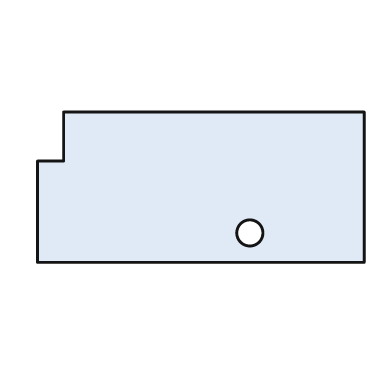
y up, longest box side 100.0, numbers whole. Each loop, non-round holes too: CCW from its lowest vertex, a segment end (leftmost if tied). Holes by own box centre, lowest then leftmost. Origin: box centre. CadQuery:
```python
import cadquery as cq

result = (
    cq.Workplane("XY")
    .moveTo(-50.0, -23.0)
    .lineTo(50.0, -23.0)
    .lineTo(50.0, 23.0)
    .lineTo(-42.0, 23.0)
    .lineTo(-42.0, 8.0)
    .lineTo(-50.0, 8.0)
    .close()
    .moveTo(15.0, -14.0)
    .circle(4.0)
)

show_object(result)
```